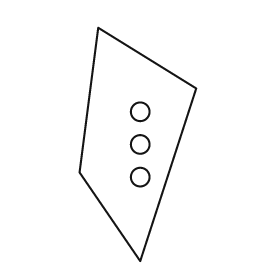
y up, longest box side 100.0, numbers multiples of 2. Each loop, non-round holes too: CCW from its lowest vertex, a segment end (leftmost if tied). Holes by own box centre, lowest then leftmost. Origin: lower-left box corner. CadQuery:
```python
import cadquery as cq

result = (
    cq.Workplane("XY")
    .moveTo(26.0, 0.0)
    .lineTo(50.0, 74.0)
    .lineTo(8.0, 100.0)
    .lineTo(0.0, 38.0)
    .close()
    .moveTo(26.0, 36.0)
    .circle(4.0)
    .moveTo(26.0, 50.0)
    .circle(4.0)
    .moveTo(26.0, 64.0)
    .circle(4.0)
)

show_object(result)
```